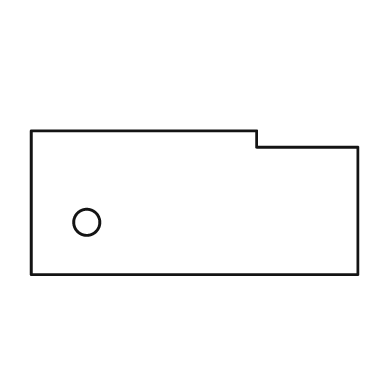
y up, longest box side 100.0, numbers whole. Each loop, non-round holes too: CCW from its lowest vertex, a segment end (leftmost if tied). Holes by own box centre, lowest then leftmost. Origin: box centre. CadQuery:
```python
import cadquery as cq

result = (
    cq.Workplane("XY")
    .moveTo(-50.0, -22.0)
    .lineTo(50.0, -22.0)
    .lineTo(50.0, 17.0)
    .lineTo(19.0, 17.0)
    .lineTo(19.0, 22.0)
    .lineTo(-50.0, 22.0)
    .close()
    .moveTo(-33.0, -6.0)
    .circle(4.0)
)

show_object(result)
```